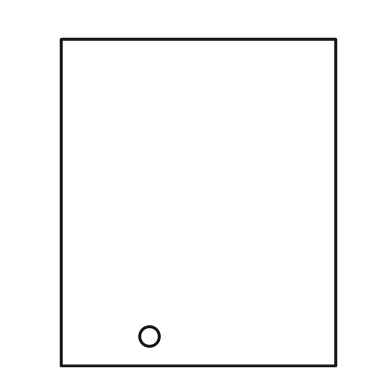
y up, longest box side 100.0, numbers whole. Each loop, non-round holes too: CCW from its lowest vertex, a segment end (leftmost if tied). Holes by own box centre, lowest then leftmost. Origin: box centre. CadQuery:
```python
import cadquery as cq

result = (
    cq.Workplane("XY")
    .moveTo(-42.0, -50.0)
    .lineTo(42.0, -50.0)
    .lineTo(42.0, 50.0)
    .lineTo(-42.0, 50.0)
    .close()
    .moveTo(-15.0, -41.0)
    .circle(3.0)
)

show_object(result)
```